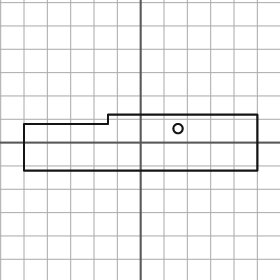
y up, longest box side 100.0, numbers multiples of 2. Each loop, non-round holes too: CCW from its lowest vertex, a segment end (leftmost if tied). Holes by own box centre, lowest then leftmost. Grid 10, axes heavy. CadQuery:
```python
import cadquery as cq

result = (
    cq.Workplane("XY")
    .moveTo(-50.0, -12.0)
    .lineTo(50.0, -12.0)
    .lineTo(50.0, 12.0)
    .lineTo(-14.0, 12.0)
    .lineTo(-14.0, 8.0)
    .lineTo(-50.0, 8.0)
    .close()
    .moveTo(16.0, 6.0)
    .circle(2.0)
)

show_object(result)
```